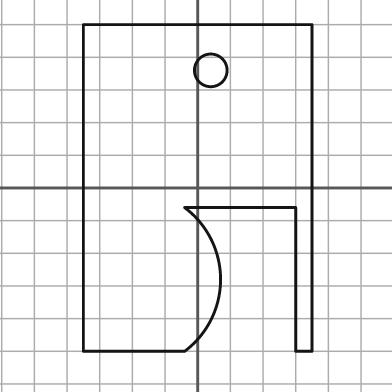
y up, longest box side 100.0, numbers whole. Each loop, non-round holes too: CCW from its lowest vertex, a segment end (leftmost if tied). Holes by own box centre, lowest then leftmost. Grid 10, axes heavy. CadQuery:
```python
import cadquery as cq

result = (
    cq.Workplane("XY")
    .moveTo(-35.0, -50.0)
    .lineTo(-4.0, -50.0)
    .threePointArc((7.0, -28.0), (-4.0, -6.0))
    .lineTo(30.0, -6.0)
    .lineTo(30.0, -50.0)
    .lineTo(35.0, -50.0)
    .lineTo(35.0, 50.0)
    .lineTo(-35.0, 50.0)
    .close()
    .moveTo(4.0, 36.0)
    .circle(5.0)
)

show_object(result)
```